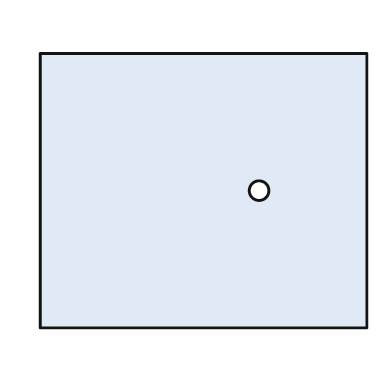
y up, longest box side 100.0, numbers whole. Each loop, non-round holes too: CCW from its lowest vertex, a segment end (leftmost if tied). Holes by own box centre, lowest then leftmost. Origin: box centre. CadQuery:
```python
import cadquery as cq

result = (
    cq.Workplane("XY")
    .moveTo(-50.0, -42.0)
    .lineTo(50.0, -42.0)
    .lineTo(50.0, 42.0)
    .lineTo(-50.0, 42.0)
    .close()
    .moveTo(17.0, 0.0)
    .circle(3.0)
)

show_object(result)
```